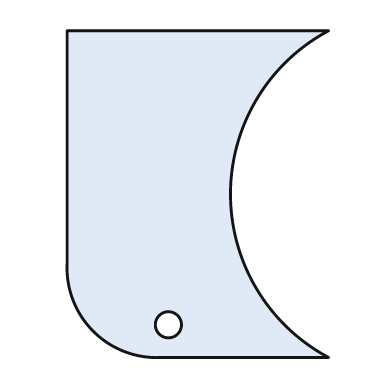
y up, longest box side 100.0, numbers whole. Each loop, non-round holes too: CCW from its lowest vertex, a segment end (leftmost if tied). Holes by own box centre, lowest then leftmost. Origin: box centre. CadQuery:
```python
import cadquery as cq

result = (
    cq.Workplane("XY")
    .moveTo(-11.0, -50.0)
    .lineTo(40.0, -50.0)
    .threePointArc((10.0, 0.0), (40.0, 50.0))
    .lineTo(-40.0, 50.0)
    .lineTo(-40.0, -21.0)
    .threePointArc((-32.0, -42.0), (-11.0, -50.0))
    .close()
    .moveTo(-9.0, -40.0)
    .circle(4.0)
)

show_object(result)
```